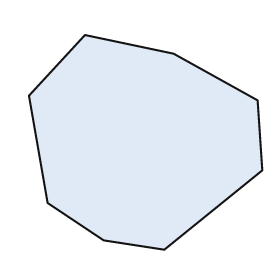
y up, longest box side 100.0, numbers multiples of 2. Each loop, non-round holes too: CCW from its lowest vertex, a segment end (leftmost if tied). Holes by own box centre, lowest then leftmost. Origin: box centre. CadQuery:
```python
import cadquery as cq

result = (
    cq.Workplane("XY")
    .moveTo(8.0, -46.0)
    .lineTo(50.0, -12.0)
    .lineTo(48.0, 18.0)
    .lineTo(12.0, 38.0)
    .lineTo(-26.0, 46.0)
    .lineTo(-50.0, 20.0)
    .lineTo(-42.0, -26.0)
    .lineTo(-18.0, -42.0)
    .close()
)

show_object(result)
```